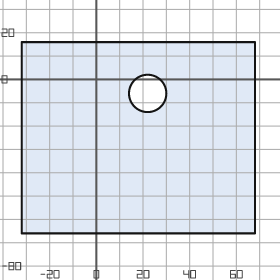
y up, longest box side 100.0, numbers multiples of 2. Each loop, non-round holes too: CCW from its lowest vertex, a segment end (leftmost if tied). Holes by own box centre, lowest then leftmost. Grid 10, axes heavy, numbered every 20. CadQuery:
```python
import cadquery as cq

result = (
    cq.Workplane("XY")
    .moveTo(-32.0, -66.0)
    .lineTo(68.0, -66.0)
    .lineTo(68.0, 16.0)
    .lineTo(-32.0, 16.0)
    .close()
    .moveTo(22.0, -6.0)
    .circle(8.0)
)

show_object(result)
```